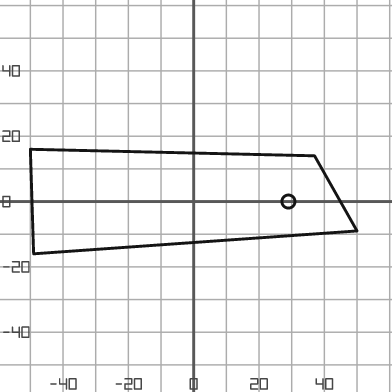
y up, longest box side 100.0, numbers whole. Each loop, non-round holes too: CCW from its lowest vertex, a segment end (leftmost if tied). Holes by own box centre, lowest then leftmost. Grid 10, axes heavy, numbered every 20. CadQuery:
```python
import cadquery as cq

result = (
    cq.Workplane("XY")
    .moveTo(-49.0, -16.0)
    .lineTo(50.0, -9.0)
    .lineTo(37.0, 14.0)
    .lineTo(-50.0, 16.0)
    .close()
    .moveTo(29.0, 0.0)
    .circle(2.0)
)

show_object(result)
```